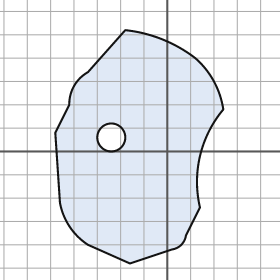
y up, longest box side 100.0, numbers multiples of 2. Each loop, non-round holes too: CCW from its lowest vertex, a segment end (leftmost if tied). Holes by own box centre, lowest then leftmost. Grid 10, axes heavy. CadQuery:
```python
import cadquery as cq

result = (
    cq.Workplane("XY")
    .moveTo(-16.0, -48.0)
    .lineTo(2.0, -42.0)
    .threePointArc((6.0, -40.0), (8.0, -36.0))
    .lineTo(14.0, -24.0)
    .threePointArc((14.0, -2.0), (24.0, 18.0))
    .threePointArc((20.0, 30.0), (12.0, 40.0))
    .threePointArc((-2.0, 48.0), (-18.0, 52.0))
    .lineTo(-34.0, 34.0)
    .threePointArc((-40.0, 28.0), (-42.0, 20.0))
    .lineTo(-48.0, 8.0)
    .lineTo(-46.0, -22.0)
    .threePointArc((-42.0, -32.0), (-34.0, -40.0))
    .close()
    .moveTo(-24.0, 6.0)
    .circle(6.0)
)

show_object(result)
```